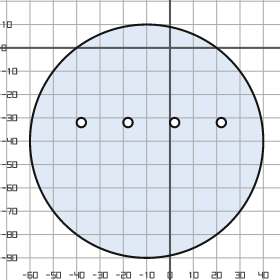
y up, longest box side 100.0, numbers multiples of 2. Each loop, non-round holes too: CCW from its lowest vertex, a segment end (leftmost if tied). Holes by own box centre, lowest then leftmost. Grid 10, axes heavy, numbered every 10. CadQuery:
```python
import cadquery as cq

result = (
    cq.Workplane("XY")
    .moveTo(-10.0, -40.0)
    .circle(50.0)
    .moveTo(-38.0, -32.0)
    .circle(2.0)
    .moveTo(-18.0, -32.0)
    .circle(2.0)
    .moveTo(2.0, -32.0)
    .circle(2.0)
    .moveTo(22.0, -32.0)
    .circle(2.0)
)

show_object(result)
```